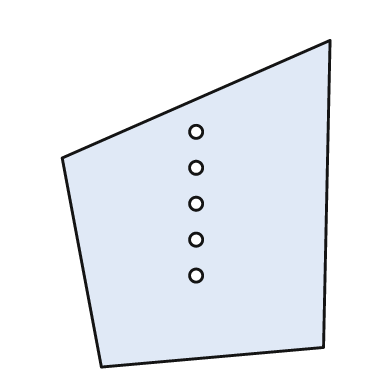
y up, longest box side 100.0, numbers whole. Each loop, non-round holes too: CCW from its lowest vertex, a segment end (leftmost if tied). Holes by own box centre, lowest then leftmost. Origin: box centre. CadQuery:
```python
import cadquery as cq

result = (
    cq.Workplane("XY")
    .moveTo(-29.0, -50.0)
    .lineTo(39.0, -44.0)
    .lineTo(41.0, 50.0)
    .lineTo(-41.0, 14.0)
    .close()
    .moveTo(0.0, -22.0)
    .circle(2.0)
    .moveTo(0.0, -11.0)
    .circle(2.0)
    .moveTo(0.0, 0.0)
    .circle(2.0)
    .moveTo(0.0, 11.0)
    .circle(2.0)
    .moveTo(0.0, 22.0)
    .circle(2.0)
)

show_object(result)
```